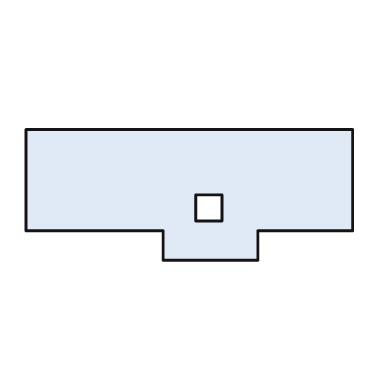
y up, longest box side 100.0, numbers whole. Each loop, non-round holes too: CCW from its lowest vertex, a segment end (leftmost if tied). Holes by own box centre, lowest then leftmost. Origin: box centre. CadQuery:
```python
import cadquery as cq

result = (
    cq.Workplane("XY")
    .moveTo(-8.0, -20.0)
    .lineTo(21.0, -20.0)
    .lineTo(21.0, -11.0)
    .lineTo(50.0, -11.0)
    .lineTo(50.0, 20.0)
    .lineTo(-50.0, 20.0)
    .lineTo(-50.0, -11.0)
    .lineTo(-8.0, -11.0)
    .close()
    .moveTo(2.0, -8.0)
    .lineTo(10.0, -8.0)
    .lineTo(10.0, 0.0)
    .lineTo(2.0, 0.0)
    .close()
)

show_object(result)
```